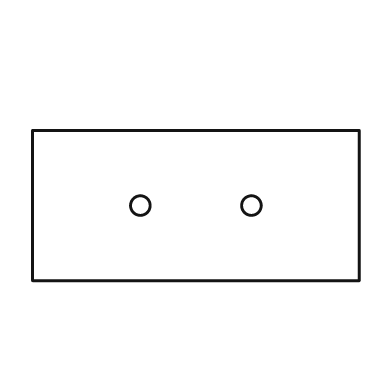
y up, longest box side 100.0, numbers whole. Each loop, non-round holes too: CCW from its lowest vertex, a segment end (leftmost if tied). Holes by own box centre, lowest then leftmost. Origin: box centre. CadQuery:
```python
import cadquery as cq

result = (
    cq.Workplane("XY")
    .moveTo(-50.0, -23.0)
    .lineTo(50.0, -23.0)
    .lineTo(50.0, 23.0)
    .lineTo(-50.0, 23.0)
    .close()
    .moveTo(-17.0, 0.0)
    .circle(3.0)
    .moveTo(17.0, 0.0)
    .circle(3.0)
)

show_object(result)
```